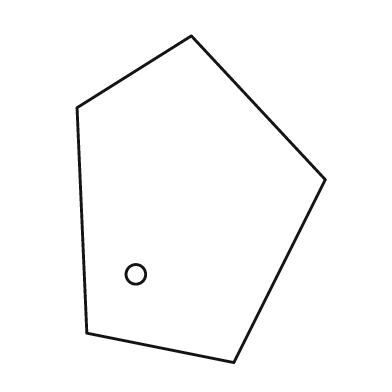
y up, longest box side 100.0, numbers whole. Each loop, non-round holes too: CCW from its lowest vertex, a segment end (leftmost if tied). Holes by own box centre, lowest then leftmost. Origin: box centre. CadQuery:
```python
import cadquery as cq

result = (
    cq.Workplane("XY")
    .moveTo(10.0, -50.0)
    .lineTo(38.0, 6.0)
    .lineTo(-3.0, 50.0)
    .lineTo(-38.0, 28.0)
    .lineTo(-35.0, -41.0)
    .close()
    .moveTo(-20.0, -23.0)
    .circle(3.0)
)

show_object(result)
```